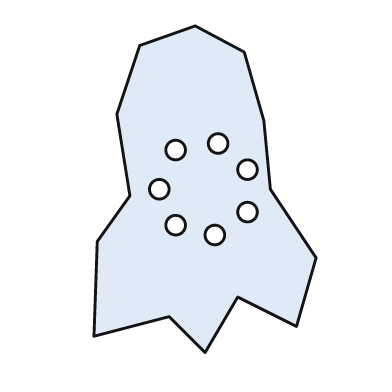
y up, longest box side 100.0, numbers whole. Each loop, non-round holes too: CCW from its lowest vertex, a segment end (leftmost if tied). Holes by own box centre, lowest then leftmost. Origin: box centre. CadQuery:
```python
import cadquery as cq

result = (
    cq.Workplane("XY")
    .moveTo(0.0, -50.0)
    .lineTo(10.0, -33.0)
    .lineTo(28.0, -42.0)
    .lineTo(34.0, -21.0)
    .lineTo(20.0, 0.0)
    .lineTo(18.0, 21.0)
    .lineTo(12.0, 42.0)
    .lineTo(-3.0, 50.0)
    .lineTo(-20.0, 44.0)
    .lineTo(-27.0, 23.0)
    .lineTo(-23.0, -2.0)
    .lineTo(-33.0, -16.0)
    .lineTo(-34.0, -45.0)
    .lineTo(-11.0, -39.0)
    .close()
    .moveTo(3.0, -14.0)
    .circle(3.0)
    .moveTo(-9.0, -11.0)
    .circle(3.0)
    .moveTo(13.0, -7.0)
    .circle(3.0)
    .moveTo(-14.0, 0.0)
    .circle(3.0)
    .moveTo(13.0, 6.0)
    .circle(3.0)
    .moveTo(-9.0, 12.0)
    .circle(3.0)
    .moveTo(4.0, 14.0)
    .circle(3.0)
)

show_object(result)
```